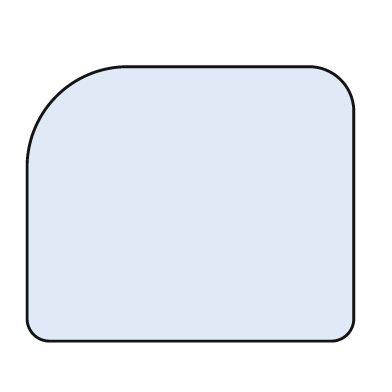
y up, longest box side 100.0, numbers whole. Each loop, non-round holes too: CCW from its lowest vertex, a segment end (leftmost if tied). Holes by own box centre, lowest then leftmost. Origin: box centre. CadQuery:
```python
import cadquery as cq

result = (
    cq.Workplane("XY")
    .moveTo(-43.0, -42.0)
    .lineTo(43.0, -42.0)
    .threePointArc((48.0, -40.0), (50.0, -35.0))
    .lineTo(50.0, 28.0)
    .threePointArc((46.0, 38.0), (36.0, 42.0))
    .lineTo(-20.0, 42.0)
    .threePointArc((-41.0, 33.0), (-50.0, 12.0))
    .lineTo(-50.0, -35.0)
    .threePointArc((-48.0, -40.0), (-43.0, -42.0))
    .close()
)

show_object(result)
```